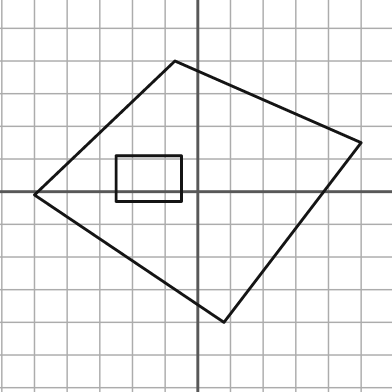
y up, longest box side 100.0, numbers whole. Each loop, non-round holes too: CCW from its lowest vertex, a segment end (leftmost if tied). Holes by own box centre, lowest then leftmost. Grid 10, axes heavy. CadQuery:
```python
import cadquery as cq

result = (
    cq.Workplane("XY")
    .moveTo(8.0, -40.0)
    .lineTo(50.0, 15.0)
    .lineTo(-7.0, 40.0)
    .lineTo(-50.0, -1.0)
    .close()
    .moveTo(-25.0, -3.0)
    .lineTo(-5.0, -3.0)
    .lineTo(-5.0, 11.0)
    .lineTo(-25.0, 11.0)
    .close()
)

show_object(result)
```